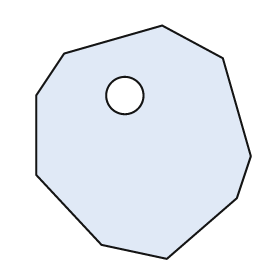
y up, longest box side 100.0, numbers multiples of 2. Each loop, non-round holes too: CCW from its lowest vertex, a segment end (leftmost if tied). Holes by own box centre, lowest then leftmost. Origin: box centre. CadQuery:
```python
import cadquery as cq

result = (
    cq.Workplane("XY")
    .moveTo(10.0, -50.0)
    .lineTo(40.0, -24.0)
    .lineTo(46.0, -6.0)
    .lineTo(34.0, 36.0)
    .lineTo(8.0, 50.0)
    .lineTo(-34.0, 38.0)
    .lineTo(-46.0, 20.0)
    .lineTo(-46.0, -14.0)
    .lineTo(-18.0, -44.0)
    .close()
    .moveTo(-8.0, 20.0)
    .circle(8.0)
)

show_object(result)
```